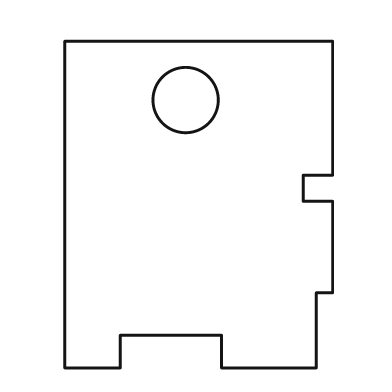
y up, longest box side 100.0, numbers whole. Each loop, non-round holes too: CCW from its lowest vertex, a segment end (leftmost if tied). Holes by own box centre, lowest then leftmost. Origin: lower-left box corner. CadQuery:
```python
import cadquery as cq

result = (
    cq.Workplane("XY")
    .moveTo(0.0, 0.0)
    .lineTo(17.0, 0.0)
    .lineTo(17.0, 10.0)
    .lineTo(48.0, 10.0)
    .lineTo(48.0, 0.0)
    .lineTo(77.0, 0.0)
    .lineTo(77.0, 23.0)
    .lineTo(82.0, 23.0)
    .lineTo(82.0, 51.0)
    .lineTo(73.0, 51.0)
    .lineTo(73.0, 59.0)
    .lineTo(82.0, 59.0)
    .lineTo(82.0, 100.0)
    .lineTo(0.0, 100.0)
    .close()
    .moveTo(37.0, 82.0)
    .circle(10.0)
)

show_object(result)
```